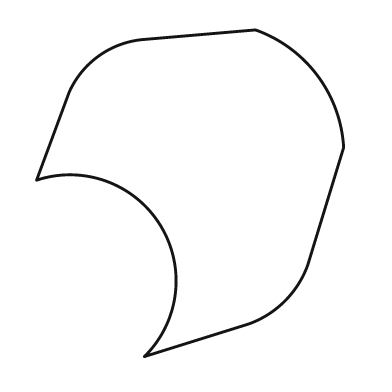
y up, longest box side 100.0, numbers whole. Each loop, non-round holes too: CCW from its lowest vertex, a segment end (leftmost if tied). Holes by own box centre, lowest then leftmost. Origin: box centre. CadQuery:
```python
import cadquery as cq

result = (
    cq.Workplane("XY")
    .moveTo(-14.0, -50.0)
    .lineTo(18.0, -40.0)
    .threePointArc((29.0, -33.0), (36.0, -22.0))
    .lineTo(47.0, 14.0)
    .threePointArc((39.0, 36.0), (20.0, 50.0))
    .lineTo(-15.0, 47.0)
    .threePointArc((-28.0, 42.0), (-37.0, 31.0))
    .lineTo(-47.0, 4.0)
    .threePointArc((-9.0, -10.0), (-14.0, -50.0))
    .close()
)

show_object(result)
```